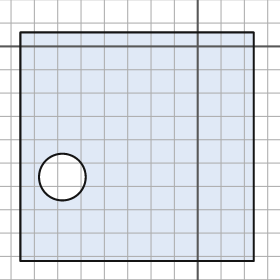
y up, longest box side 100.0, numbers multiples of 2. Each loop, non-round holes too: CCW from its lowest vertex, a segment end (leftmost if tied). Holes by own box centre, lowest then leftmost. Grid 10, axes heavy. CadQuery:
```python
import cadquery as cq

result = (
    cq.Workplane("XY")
    .moveTo(-76.0, -92.0)
    .lineTo(24.0, -92.0)
    .lineTo(24.0, 6.0)
    .lineTo(-76.0, 6.0)
    .close()
    .moveTo(-58.0, -56.0)
    .circle(10.0)
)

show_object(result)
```